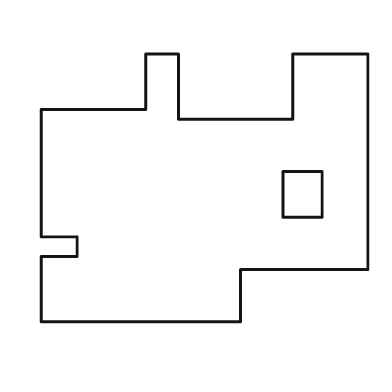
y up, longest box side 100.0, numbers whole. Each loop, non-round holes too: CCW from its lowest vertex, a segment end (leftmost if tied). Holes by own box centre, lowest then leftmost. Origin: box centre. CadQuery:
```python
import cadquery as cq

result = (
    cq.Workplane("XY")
    .moveTo(-50.0, -41.0)
    .lineTo(11.0, -41.0)
    .lineTo(11.0, -25.0)
    .lineTo(50.0, -25.0)
    .lineTo(50.0, 41.0)
    .lineTo(27.0, 41.0)
    .lineTo(27.0, 21.0)
    .lineTo(-8.0, 21.0)
    .lineTo(-8.0, 41.0)
    .lineTo(-18.0, 41.0)
    .lineTo(-18.0, 24.0)
    .lineTo(-50.0, 24.0)
    .lineTo(-50.0, -15.0)
    .lineTo(-39.0, -15.0)
    .lineTo(-39.0, -21.0)
    .lineTo(-50.0, -21.0)
    .close()
    .moveTo(24.0, -9.0)
    .lineTo(36.0, -9.0)
    .lineTo(36.0, 5.0)
    .lineTo(24.0, 5.0)
    .close()
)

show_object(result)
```